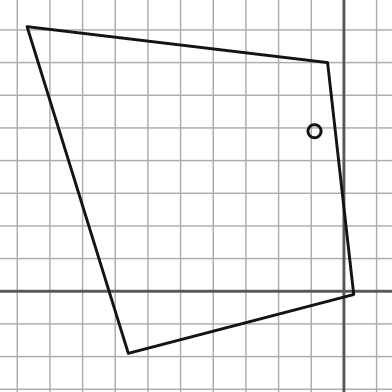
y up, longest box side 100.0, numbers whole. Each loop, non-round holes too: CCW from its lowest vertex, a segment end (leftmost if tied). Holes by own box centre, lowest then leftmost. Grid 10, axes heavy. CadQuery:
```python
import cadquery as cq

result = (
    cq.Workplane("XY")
    .moveTo(-66.0, -19.0)
    .lineTo(3.0, -1.0)
    .lineTo(-5.0, 70.0)
    .lineTo(-97.0, 81.0)
    .close()
    .moveTo(-9.0, 49.0)
    .circle(2.0)
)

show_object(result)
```